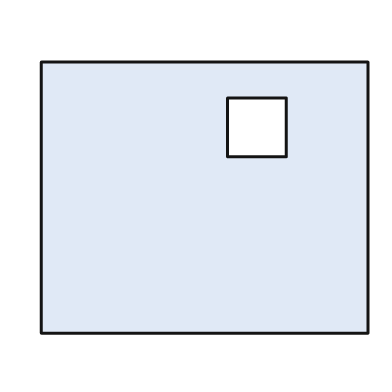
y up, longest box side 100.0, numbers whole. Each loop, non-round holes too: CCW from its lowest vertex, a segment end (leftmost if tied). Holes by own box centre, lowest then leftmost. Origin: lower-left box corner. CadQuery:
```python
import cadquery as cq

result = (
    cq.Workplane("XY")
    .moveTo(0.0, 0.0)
    .lineTo(100.0, 0.0)
    .lineTo(100.0, 83.0)
    .lineTo(0.0, 83.0)
    .close()
    .moveTo(57.0, 54.0)
    .lineTo(75.0, 54.0)
    .lineTo(75.0, 72.0)
    .lineTo(57.0, 72.0)
    .close()
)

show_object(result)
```